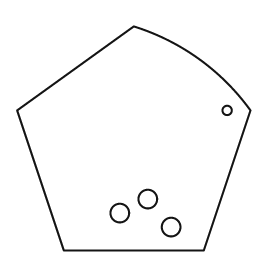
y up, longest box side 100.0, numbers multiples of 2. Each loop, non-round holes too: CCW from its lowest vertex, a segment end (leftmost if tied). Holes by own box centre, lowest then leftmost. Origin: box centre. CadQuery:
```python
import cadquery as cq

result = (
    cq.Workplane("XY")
    .moveTo(-30.0, -48.0)
    .lineTo(30.0, -48.0)
    .lineTo(50.0, 12.0)
    .threePointArc((28.0, 34.0), (0.0, 48.0))
    .lineTo(-50.0, 12.0)
    .close()
    .moveTo(16.0, -38.0)
    .circle(4.0)
    .moveTo(-6.0, -32.0)
    .circle(4.0)
    .moveTo(6.0, -26.0)
    .circle(4.0)
    .moveTo(40.0, 12.0)
    .circle(2.0)
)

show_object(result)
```